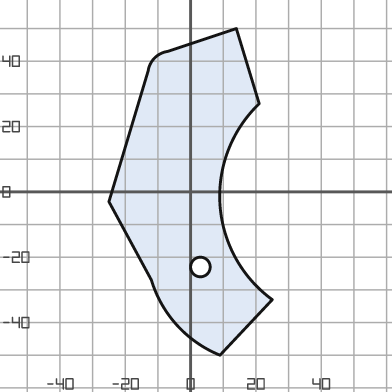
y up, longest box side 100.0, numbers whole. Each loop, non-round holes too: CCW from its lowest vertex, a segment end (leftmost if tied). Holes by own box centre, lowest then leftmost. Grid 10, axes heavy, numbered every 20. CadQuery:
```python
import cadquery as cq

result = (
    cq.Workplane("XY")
    .moveTo(9.0, -50.0)
    .lineTo(25.0, -33.0)
    .threePointArc((9.0, -4.0), (21.0, 27.0))
    .lineTo(14.0, 50.0)
    .lineTo(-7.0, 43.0)
    .threePointArc((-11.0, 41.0), (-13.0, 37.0))
    .lineTo(-25.0, -3.0)
    .lineTo(-12.0, -27.0)
    .threePointArc((-4.0, -41.0), (9.0, -50.0))
    .close()
    .moveTo(3.0, -23.0)
    .circle(3.0)
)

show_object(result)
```